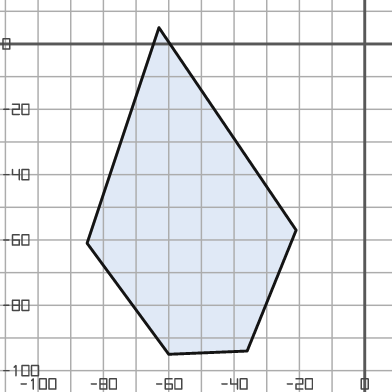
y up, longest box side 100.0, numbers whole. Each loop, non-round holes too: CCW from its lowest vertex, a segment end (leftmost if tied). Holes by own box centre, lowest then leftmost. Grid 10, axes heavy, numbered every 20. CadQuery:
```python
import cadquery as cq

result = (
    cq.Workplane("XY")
    .moveTo(-60.0, -95.0)
    .lineTo(-36.0, -94.0)
    .lineTo(-21.0, -57.0)
    .lineTo(-63.0, 5.0)
    .lineTo(-85.0, -61.0)
    .close()
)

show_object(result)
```